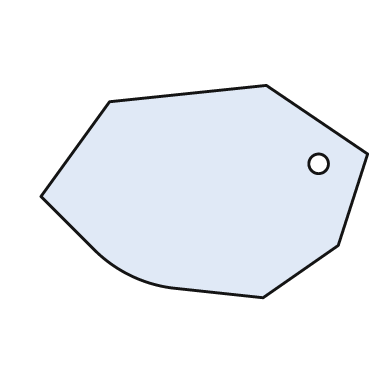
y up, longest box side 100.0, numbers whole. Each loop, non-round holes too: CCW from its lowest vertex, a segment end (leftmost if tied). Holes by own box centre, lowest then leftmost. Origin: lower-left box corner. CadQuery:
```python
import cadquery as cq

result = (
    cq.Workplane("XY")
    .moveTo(68.0, 0.0)
    .lineTo(91.0, 16.0)
    .lineTo(100.0, 44.0)
    .lineTo(69.0, 65.0)
    .lineTo(21.0, 60.0)
    .lineTo(0.0, 31.0)
    .lineTo(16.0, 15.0)
    .threePointArc((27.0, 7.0), (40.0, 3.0))
    .close()
    .moveTo(85.0, 41.0)
    .circle(3.0)
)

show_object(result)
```